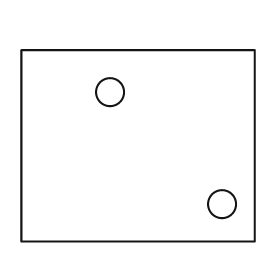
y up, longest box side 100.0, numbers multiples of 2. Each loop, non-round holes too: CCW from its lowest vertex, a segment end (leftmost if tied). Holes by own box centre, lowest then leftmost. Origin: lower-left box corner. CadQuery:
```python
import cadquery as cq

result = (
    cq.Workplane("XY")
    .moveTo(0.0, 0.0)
    .lineTo(100.0, 0.0)
    .lineTo(100.0, 82.0)
    .lineTo(0.0, 82.0)
    .close()
    .moveTo(86.0, 16.0)
    .circle(6.0)
    .moveTo(38.0, 64.0)
    .circle(6.0)
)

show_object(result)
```